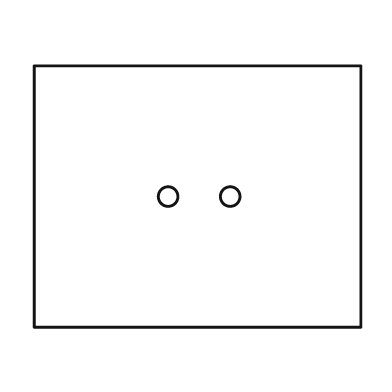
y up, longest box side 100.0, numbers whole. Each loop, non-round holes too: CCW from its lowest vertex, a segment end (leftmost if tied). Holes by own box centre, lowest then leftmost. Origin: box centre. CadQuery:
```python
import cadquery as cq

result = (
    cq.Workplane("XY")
    .moveTo(-50.0, -40.0)
    .lineTo(50.0, -40.0)
    .lineTo(50.0, 40.0)
    .lineTo(-50.0, 40.0)
    .close()
    .moveTo(-9.0, 0.0)
    .circle(3.0)
    .moveTo(10.0, 0.0)
    .circle(3.0)
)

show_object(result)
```